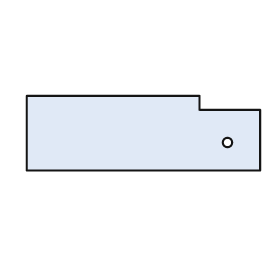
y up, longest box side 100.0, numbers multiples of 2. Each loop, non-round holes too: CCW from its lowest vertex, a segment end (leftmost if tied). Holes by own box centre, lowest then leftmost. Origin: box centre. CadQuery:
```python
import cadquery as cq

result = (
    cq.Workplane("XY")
    .moveTo(-50.0, -16.0)
    .lineTo(50.0, -16.0)
    .lineTo(50.0, 10.0)
    .lineTo(24.0, 10.0)
    .lineTo(24.0, 16.0)
    .lineTo(-50.0, 16.0)
    .close()
    .moveTo(36.0, -4.0)
    .circle(2.0)
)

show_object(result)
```